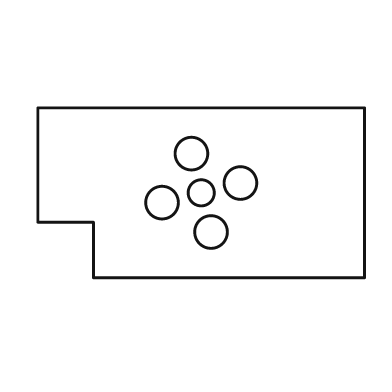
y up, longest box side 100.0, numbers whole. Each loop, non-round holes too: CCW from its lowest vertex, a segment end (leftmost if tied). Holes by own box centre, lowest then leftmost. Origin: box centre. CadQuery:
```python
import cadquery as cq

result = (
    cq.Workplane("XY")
    .moveTo(-33.0, -26.0)
    .lineTo(50.0, -26.0)
    .lineTo(50.0, 26.0)
    .lineTo(-50.0, 26.0)
    .lineTo(-50.0, -9.0)
    .lineTo(-33.0, -9.0)
    .close()
    .moveTo(3.0, -12.0)
    .circle(5.0)
    .moveTo(-12.0, -3.0)
    .circle(5.0)
    .moveTo(0.0, 0.0)
    .circle(4.0)
    .moveTo(12.0, 3.0)
    .circle(5.0)
    .moveTo(-3.0, 12.0)
    .circle(5.0)
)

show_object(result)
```